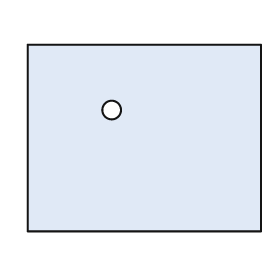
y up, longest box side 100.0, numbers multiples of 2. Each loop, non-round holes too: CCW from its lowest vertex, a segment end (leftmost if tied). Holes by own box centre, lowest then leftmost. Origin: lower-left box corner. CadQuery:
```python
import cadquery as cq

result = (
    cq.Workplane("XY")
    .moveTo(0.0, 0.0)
    .lineTo(100.0, 0.0)
    .lineTo(100.0, 80.0)
    .lineTo(0.0, 80.0)
    .close()
    .moveTo(36.0, 52.0)
    .circle(4.0)
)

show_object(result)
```